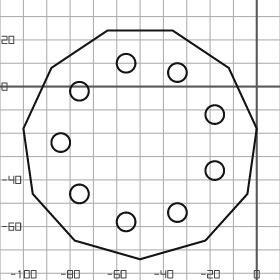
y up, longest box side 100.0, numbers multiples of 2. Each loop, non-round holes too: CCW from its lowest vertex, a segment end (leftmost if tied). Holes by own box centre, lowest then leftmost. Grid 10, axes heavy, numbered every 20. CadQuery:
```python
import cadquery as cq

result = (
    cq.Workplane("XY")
    .moveTo(-50.0, -74.0)
    .lineTo(-22.0, -66.0)
    .lineTo(-4.0, -46.0)
    .lineTo(0.0, -18.0)
    .lineTo(-12.0, 8.0)
    .lineTo(-36.0, 24.0)
    .lineTo(-64.0, 24.0)
    .lineTo(-88.0, 8.0)
    .lineTo(-100.0, -18.0)
    .lineTo(-96.0, -46.0)
    .lineTo(-78.0, -66.0)
    .close()
    .moveTo(-56.0, -58.0)
    .circle(4.0)
    .moveTo(-34.0, -54.0)
    .circle(4.0)
    .moveTo(-76.0, -46.0)
    .circle(4.0)
    .moveTo(-18.0, -36.0)
    .circle(4.0)
    .moveTo(-84.0, -24.0)
    .circle(4.0)
    .moveTo(-18.0, -12.0)
    .circle(4.0)
    .moveTo(-76.0, -2.0)
    .circle(4.0)
    .moveTo(-34.0, 6.0)
    .circle(4.0)
    .moveTo(-56.0, 10.0)
    .circle(4.0)
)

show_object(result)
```